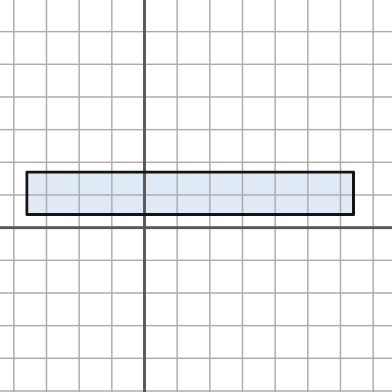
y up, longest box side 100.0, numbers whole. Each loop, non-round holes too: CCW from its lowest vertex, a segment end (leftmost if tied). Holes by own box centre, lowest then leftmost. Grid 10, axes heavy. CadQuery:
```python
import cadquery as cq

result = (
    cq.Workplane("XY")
    .moveTo(-36.0, 4.0)
    .lineTo(64.0, 4.0)
    .lineTo(64.0, 17.0)
    .lineTo(-36.0, 17.0)
    .close()
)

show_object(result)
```